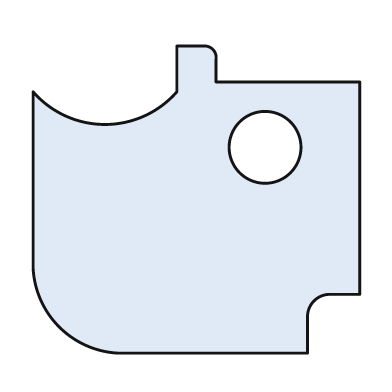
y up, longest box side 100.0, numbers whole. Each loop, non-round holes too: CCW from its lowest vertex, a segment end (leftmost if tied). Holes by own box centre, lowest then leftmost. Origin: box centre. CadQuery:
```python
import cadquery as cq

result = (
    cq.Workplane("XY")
    .moveTo(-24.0, -47.0)
    .lineTo(34.0, -47.0)
    .lineTo(34.0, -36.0)
    .threePointArc((36.0, -31.0), (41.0, -29.0))
    .lineTo(50.0, -29.0)
    .lineTo(50.0, 36.0)
    .lineTo(6.0, 36.0)
    .lineTo(6.0, 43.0)
    .threePointArc((5.0, 46.0), (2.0, 47.0))
    .lineTo(-6.0, 47.0)
    .lineTo(-6.0, 33.0)
    .threePointArc((-28.0, 23.0), (-50.0, 33.0))
    .lineTo(-50.0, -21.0)
    .threePointArc((-42.0, -39.0), (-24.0, -47.0))
    .close()
    .moveTo(21.0, 16.0)
    .circle(11.0)
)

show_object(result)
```